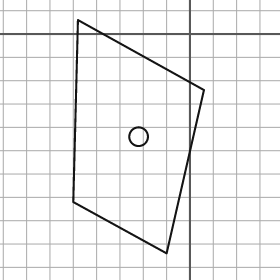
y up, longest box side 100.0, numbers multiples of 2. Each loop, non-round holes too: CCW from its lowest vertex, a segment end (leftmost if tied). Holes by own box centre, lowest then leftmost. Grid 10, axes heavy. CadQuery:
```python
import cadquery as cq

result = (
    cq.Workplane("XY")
    .moveTo(-10.0, -94.0)
    .lineTo(6.0, -24.0)
    .lineTo(-48.0, 6.0)
    .lineTo(-50.0, -72.0)
    .close()
    .moveTo(-22.0, -44.0)
    .circle(4.0)
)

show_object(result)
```